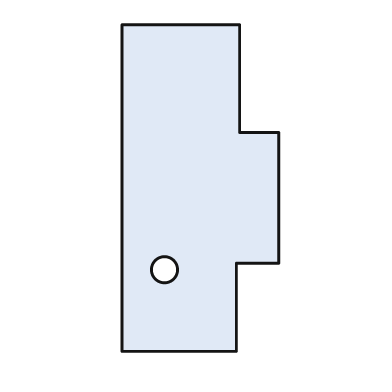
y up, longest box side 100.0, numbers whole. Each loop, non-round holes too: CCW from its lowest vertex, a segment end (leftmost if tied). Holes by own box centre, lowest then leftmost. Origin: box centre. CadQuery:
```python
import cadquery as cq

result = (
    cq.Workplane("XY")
    .moveTo(-24.0, -50.0)
    .lineTo(11.0, -50.0)
    .lineTo(11.0, -23.0)
    .lineTo(24.0, -23.0)
    .lineTo(24.0, 17.0)
    .lineTo(12.0, 17.0)
    .lineTo(12.0, 50.0)
    .lineTo(-24.0, 50.0)
    .close()
    .moveTo(-11.0, -25.0)
    .circle(4.0)
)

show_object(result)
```